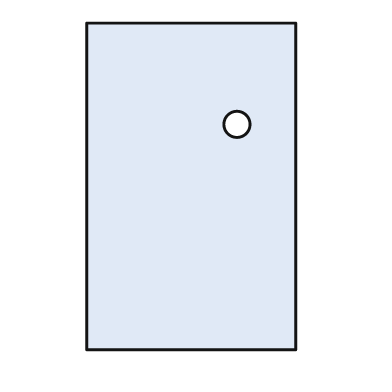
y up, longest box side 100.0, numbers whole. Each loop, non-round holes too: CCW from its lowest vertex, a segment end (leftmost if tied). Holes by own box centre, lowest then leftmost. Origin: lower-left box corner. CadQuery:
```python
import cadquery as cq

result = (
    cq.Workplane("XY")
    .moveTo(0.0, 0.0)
    .lineTo(64.0, 0.0)
    .lineTo(64.0, 100.0)
    .lineTo(0.0, 100.0)
    .close()
    .moveTo(46.0, 69.0)
    .circle(4.0)
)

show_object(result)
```